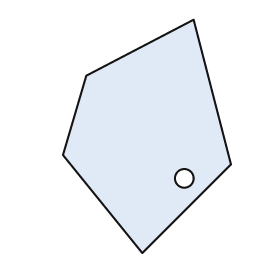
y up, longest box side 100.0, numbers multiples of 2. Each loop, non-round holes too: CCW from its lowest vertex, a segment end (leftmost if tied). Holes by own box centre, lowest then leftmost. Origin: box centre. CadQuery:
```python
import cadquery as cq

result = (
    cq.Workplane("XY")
    .moveTo(-2.0, -50.0)
    .lineTo(36.0, -12.0)
    .lineTo(20.0, 50.0)
    .lineTo(-26.0, 26.0)
    .lineTo(-36.0, -8.0)
    .close()
    .moveTo(16.0, -18.0)
    .circle(4.0)
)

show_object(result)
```